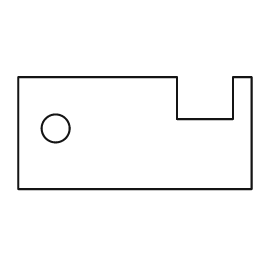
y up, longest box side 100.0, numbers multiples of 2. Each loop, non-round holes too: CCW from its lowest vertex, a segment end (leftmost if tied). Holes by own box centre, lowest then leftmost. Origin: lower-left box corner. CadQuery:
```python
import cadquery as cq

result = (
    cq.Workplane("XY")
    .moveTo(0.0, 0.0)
    .lineTo(100.0, 0.0)
    .lineTo(100.0, 48.0)
    .lineTo(92.0, 48.0)
    .lineTo(92.0, 30.0)
    .lineTo(68.0, 30.0)
    .lineTo(68.0, 48.0)
    .lineTo(0.0, 48.0)
    .close()
    .moveTo(16.0, 26.0)
    .circle(6.0)
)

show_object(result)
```